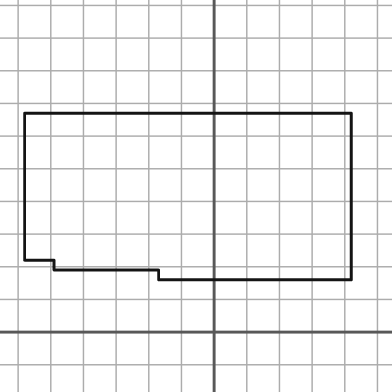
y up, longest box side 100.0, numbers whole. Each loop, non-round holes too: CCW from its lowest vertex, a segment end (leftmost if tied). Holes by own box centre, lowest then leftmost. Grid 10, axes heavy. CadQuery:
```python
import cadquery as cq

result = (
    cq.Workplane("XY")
    .moveTo(-17.0, 16.0)
    .lineTo(42.0, 16.0)
    .lineTo(42.0, 67.0)
    .lineTo(-58.0, 67.0)
    .lineTo(-58.0, 22.0)
    .lineTo(-49.0, 22.0)
    .lineTo(-49.0, 19.0)
    .lineTo(-17.0, 19.0)
    .close()
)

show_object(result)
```